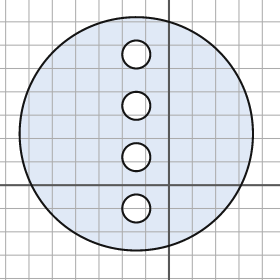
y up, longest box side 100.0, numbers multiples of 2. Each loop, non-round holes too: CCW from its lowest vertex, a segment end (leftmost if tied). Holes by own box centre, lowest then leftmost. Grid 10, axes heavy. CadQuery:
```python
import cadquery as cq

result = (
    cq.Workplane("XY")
    .moveTo(-14.0, 22.0)
    .circle(50.0)
    .moveTo(-14.0, -10.0)
    .circle(6.0)
    .moveTo(-14.0, 12.0)
    .circle(6.0)
    .moveTo(-14.0, 34.0)
    .circle(6.0)
    .moveTo(-14.0, 56.0)
    .circle(6.0)
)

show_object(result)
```